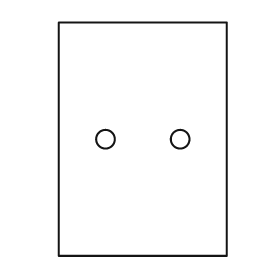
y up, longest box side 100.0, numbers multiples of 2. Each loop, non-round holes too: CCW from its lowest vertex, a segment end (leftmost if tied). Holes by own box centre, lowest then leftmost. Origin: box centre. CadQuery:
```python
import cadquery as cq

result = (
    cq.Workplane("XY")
    .moveTo(-36.0, -50.0)
    .lineTo(36.0, -50.0)
    .lineTo(36.0, 50.0)
    .lineTo(-36.0, 50.0)
    .close()
    .moveTo(-16.0, 0.0)
    .circle(4.0)
    .moveTo(16.0, 0.0)
    .circle(4.0)
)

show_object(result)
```